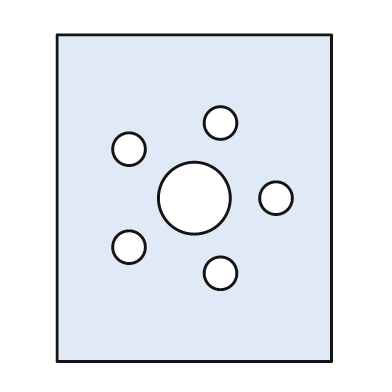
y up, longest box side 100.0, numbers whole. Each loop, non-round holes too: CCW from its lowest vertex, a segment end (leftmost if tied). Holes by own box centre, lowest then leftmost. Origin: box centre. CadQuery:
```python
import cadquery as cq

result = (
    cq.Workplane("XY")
    .moveTo(-42.0, -50.0)
    .lineTo(42.0, -50.0)
    .lineTo(42.0, 50.0)
    .lineTo(-42.0, 50.0)
    .close()
    .moveTo(8.0, -23.0)
    .circle(5.0)
    .moveTo(-20.0, -15.0)
    .circle(5.0)
    .moveTo(0.0, 0.0)
    .circle(11.0)
    .moveTo(25.0, 0.0)
    .circle(5.0)
    .moveTo(-20.0, 15.0)
    .circle(5.0)
    .moveTo(8.0, 23.0)
    .circle(5.0)
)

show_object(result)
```